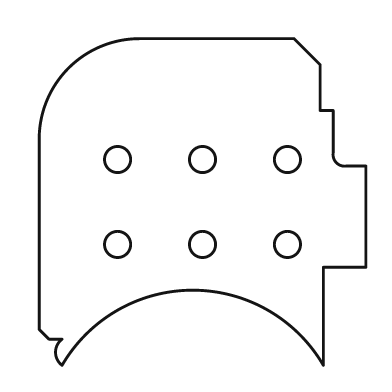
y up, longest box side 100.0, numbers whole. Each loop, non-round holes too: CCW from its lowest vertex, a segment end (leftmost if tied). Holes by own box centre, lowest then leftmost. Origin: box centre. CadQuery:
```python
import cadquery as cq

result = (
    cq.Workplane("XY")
    .moveTo(-43.0, -50.0)
    .threePointArc((-3.0, -27.0), (37.0, -50.0))
    .lineTo(37.0, -20.0)
    .lineTo(50.0, -20.0)
    .lineTo(50.0, 11.0)
    .lineTo(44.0, 11.0)
    .threePointArc((41.0, 12.0), (40.0, 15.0))
    .lineTo(40.0, 28.0)
    .lineTo(36.0, 28.0)
    .lineTo(36.0, 42.0)
    .lineTo(28.0, 50.0)
    .lineTo(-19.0, 50.0)
    .threePointArc((-41.0, 41.0), (-50.0, 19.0))
    .lineTo(-50.0, -39.0)
    .lineTo(-47.0, -42.0)
    .lineTo(-43.0, -42.0)
    .threePointArc((-45.0, -46.0), (-43.0, -50.0))
    .close()
    .moveTo(-26.0, -13.0)
    .circle(4.0)
    .moveTo(0.0, -13.0)
    .circle(4.0)
    .moveTo(26.0, -13.0)
    .circle(4.0)
    .moveTo(-26.0, 13.0)
    .circle(4.0)
    .moveTo(0.0, 13.0)
    .circle(4.0)
    .moveTo(26.0, 13.0)
    .circle(4.0)
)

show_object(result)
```